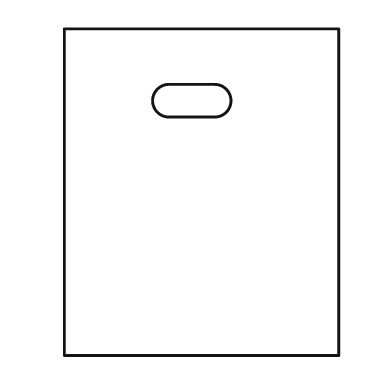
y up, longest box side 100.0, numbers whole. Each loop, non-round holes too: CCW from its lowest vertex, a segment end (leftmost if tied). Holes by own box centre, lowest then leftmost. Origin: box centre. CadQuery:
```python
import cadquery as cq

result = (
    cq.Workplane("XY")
    .moveTo(-42.0, -50.0)
    .lineTo(42.0, -50.0)
    .lineTo(42.0, 50.0)
    .lineTo(-42.0, 50.0)
    .close()
    .moveTo(-10.0, 23.0)
    .lineTo(4.0, 23.0)
    .threePointArc((9.0, 28.0), (4.0, 33.0))
    .lineTo(-10.0, 33.0)
    .threePointArc((-15.0, 28.0), (-10.0, 23.0))
    .close()
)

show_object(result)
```